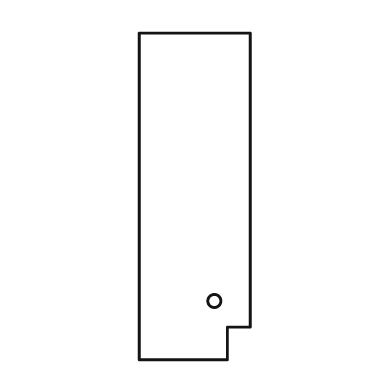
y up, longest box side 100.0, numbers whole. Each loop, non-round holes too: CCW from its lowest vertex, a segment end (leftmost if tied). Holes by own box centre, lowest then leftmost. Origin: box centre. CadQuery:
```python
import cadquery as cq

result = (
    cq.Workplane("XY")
    .moveTo(-17.0, -50.0)
    .lineTo(10.0, -50.0)
    .lineTo(10.0, -40.0)
    .lineTo(17.0, -40.0)
    .lineTo(17.0, 50.0)
    .lineTo(-17.0, 50.0)
    .close()
    .moveTo(6.0, -32.0)
    .circle(2.0)
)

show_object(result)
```